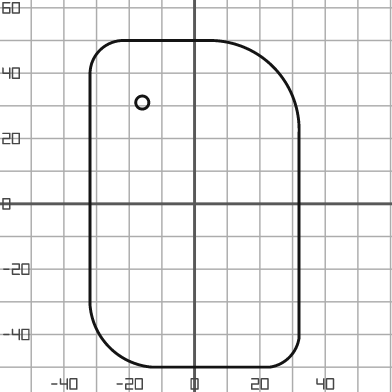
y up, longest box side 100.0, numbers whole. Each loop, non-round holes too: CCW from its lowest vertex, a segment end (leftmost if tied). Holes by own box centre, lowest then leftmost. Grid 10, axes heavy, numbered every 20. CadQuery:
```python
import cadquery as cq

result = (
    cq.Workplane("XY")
    .moveTo(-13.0, -50.0)
    .lineTo(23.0, -50.0)
    .threePointArc((29.0, -47.0), (32.0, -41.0))
    .lineTo(32.0, 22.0)
    .threePointArc((24.0, 42.0), (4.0, 50.0))
    .lineTo(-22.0, 50.0)
    .threePointArc((-29.0, 47.0), (-32.0, 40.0))
    .lineTo(-32.0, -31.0)
    .threePointArc((-26.0, -44.0), (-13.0, -50.0))
    .close()
    .moveTo(-16.0, 31.0)
    .circle(2.0)
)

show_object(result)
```